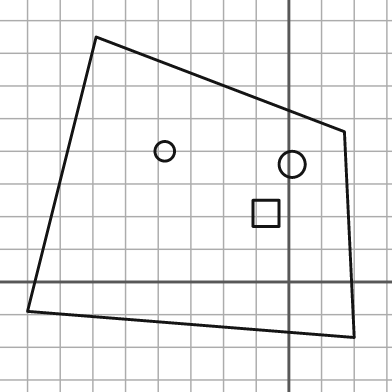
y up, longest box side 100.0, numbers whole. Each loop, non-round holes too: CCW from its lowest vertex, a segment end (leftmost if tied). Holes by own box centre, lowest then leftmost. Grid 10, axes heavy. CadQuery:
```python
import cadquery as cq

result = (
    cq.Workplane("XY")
    .moveTo(20.0, -17.0)
    .lineTo(17.0, 46.0)
    .lineTo(-59.0, 75.0)
    .lineTo(-80.0, -9.0)
    .close()
    .moveTo(-11.0, 17.0)
    .lineTo(-3.0, 17.0)
    .lineTo(-3.0, 25.0)
    .lineTo(-11.0, 25.0)
    .close()
    .moveTo(1.0, 36.0)
    .circle(4.0)
    .moveTo(-38.0, 40.0)
    .circle(3.0)
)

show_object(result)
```